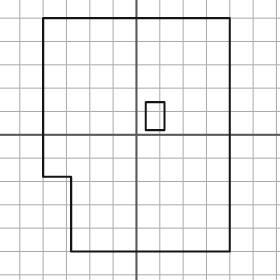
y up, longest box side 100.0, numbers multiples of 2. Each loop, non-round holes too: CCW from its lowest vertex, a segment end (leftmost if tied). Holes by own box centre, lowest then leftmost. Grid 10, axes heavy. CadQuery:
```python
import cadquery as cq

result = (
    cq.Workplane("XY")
    .moveTo(-28.0, -50.0)
    .lineTo(40.0, -50.0)
    .lineTo(40.0, 50.0)
    .lineTo(-40.0, 50.0)
    .lineTo(-40.0, -18.0)
    .lineTo(-28.0, -18.0)
    .close()
    .moveTo(4.0, 2.0)
    .lineTo(12.0, 2.0)
    .lineTo(12.0, 14.0)
    .lineTo(4.0, 14.0)
    .close()
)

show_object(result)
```